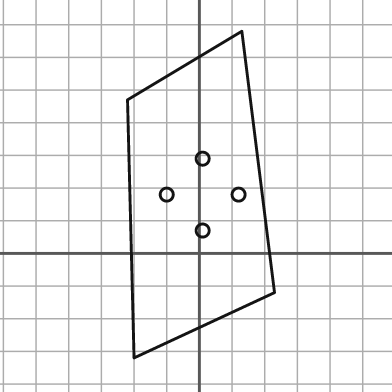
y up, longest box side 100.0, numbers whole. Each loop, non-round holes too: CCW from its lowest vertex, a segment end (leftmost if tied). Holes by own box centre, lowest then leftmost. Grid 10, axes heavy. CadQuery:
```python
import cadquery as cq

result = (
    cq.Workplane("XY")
    .moveTo(-20.0, -32.0)
    .lineTo(23.0, -12.0)
    .lineTo(13.0, 68.0)
    .lineTo(-22.0, 47.0)
    .close()
    .moveTo(1.0, 7.0)
    .circle(2.0)
    .moveTo(-10.0, 18.0)
    .circle(2.0)
    .moveTo(12.0, 18.0)
    .circle(2.0)
    .moveTo(1.0, 29.0)
    .circle(2.0)
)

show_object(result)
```